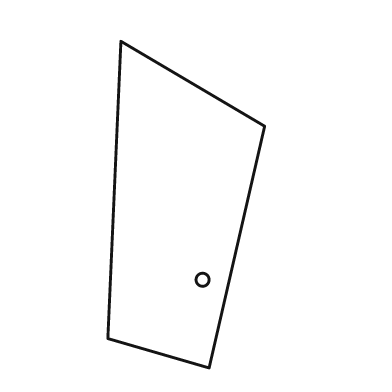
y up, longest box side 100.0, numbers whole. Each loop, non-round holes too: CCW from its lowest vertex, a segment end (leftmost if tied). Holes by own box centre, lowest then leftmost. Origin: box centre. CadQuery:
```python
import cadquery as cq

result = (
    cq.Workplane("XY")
    .moveTo(7.0, -50.0)
    .lineTo(24.0, 24.0)
    .lineTo(-20.0, 50.0)
    .lineTo(-24.0, -41.0)
    .close()
    .moveTo(5.0, -23.0)
    .circle(2.0)
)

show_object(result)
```